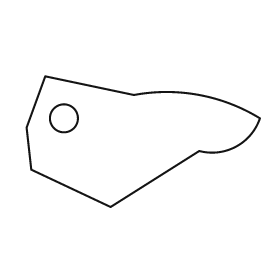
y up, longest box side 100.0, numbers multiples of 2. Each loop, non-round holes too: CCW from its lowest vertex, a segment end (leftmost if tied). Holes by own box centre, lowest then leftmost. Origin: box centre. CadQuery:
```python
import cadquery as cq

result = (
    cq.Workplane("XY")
    .moveTo(-14.0, -28.0)
    .lineTo(24.0, -4.0)
    .threePointArc((40.0, -2.0), (50.0, 10.0))
    .threePointArc((24.0, 20.0), (-4.0, 20.0))
    .lineTo(-42.0, 28.0)
    .lineTo(-50.0, 6.0)
    .lineTo(-48.0, -12.0)
    .close()
    .moveTo(-34.0, 10.0)
    .circle(6.0)
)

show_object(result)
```